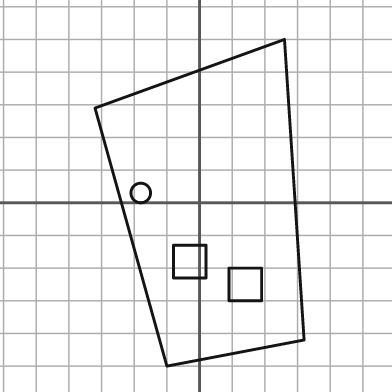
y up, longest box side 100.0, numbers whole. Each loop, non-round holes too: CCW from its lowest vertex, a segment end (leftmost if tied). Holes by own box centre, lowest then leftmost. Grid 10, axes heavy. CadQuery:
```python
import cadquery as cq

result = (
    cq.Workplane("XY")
    .moveTo(-10.0, -50.0)
    .lineTo(32.0, -42.0)
    .lineTo(26.0, 50.0)
    .lineTo(-32.0, 29.0)
    .close()
    .moveTo(9.0, -30.0)
    .lineTo(19.0, -30.0)
    .lineTo(19.0, -20.0)
    .lineTo(9.0, -20.0)
    .close()
    .moveTo(-8.0, -23.0)
    .lineTo(2.0, -23.0)
    .lineTo(2.0, -13.0)
    .lineTo(-8.0, -13.0)
    .close()
    .moveTo(-18.0, 3.0)
    .circle(3.0)
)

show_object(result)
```